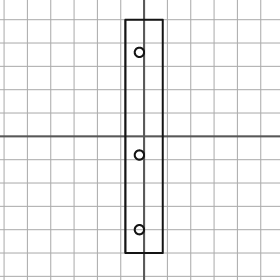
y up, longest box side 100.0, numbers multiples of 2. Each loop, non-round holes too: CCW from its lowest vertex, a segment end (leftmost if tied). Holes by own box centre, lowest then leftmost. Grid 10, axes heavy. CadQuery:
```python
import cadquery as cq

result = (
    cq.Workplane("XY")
    .moveTo(-8.0, -50.0)
    .lineTo(8.0, -50.0)
    .lineTo(8.0, 50.0)
    .lineTo(-8.0, 50.0)
    .close()
    .moveTo(-2.0, -40.0)
    .circle(2.0)
    .moveTo(-2.0, -8.0)
    .circle(2.0)
    .moveTo(-2.0, 36.0)
    .circle(2.0)
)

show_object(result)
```